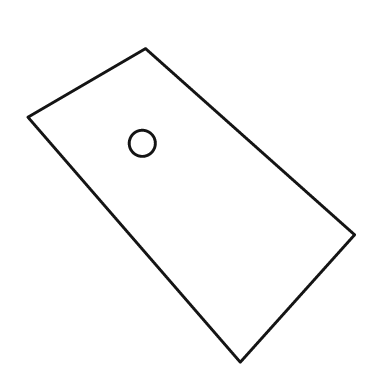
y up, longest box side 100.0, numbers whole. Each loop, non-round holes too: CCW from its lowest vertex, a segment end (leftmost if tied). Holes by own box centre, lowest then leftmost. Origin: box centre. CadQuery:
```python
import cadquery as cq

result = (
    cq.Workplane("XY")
    .moveTo(15.0, -48.0)
    .lineTo(50.0, -9.0)
    .lineTo(-14.0, 48.0)
    .lineTo(-50.0, 27.0)
    .close()
    .moveTo(-15.0, 19.0)
    .circle(4.0)
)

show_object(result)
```